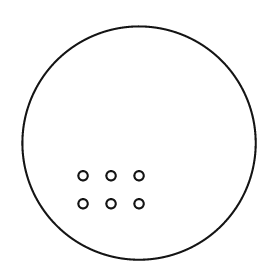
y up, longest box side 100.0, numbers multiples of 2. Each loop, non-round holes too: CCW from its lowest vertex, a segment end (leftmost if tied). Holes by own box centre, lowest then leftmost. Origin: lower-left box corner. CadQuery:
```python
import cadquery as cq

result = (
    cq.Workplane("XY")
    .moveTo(50.0, 50.0)
    .circle(50.0)
    .moveTo(26.0, 24.0)
    .circle(2.0)
    .moveTo(38.0, 24.0)
    .circle(2.0)
    .moveTo(50.0, 24.0)
    .circle(2.0)
    .moveTo(26.0, 36.0)
    .circle(2.0)
    .moveTo(38.0, 36.0)
    .circle(2.0)
    .moveTo(50.0, 36.0)
    .circle(2.0)
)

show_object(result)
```